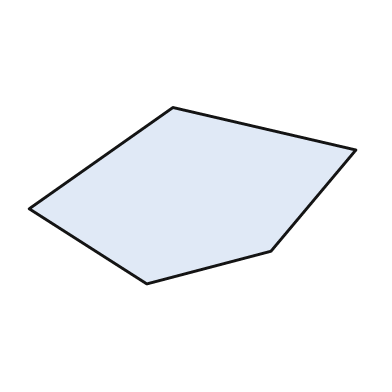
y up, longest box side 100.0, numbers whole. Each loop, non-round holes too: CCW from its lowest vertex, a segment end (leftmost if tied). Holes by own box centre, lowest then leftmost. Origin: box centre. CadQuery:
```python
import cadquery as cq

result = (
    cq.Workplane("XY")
    .moveTo(-14.0, -27.0)
    .lineTo(24.0, -17.0)
    .lineTo(50.0, 14.0)
    .lineTo(-6.0, 27.0)
    .lineTo(-50.0, -4.0)
    .close()
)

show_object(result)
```